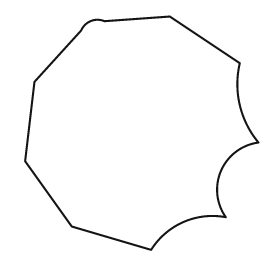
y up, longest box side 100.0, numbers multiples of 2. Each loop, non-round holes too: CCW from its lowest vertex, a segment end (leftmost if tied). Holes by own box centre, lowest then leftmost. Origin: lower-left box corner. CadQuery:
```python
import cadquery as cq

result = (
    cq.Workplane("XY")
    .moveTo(54.0, 0.0)
    .threePointArc((68.0, 12.0), (86.0, 14.0))
    .threePointArc((84.0, 34.0), (100.0, 46.0))
    .threePointArc((92.0, 62.0), (92.0, 80.0))
    .lineTo(62.0, 100.0)
    .lineTo(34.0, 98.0)
    .threePointArc((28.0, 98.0), (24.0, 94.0))
    .lineTo(4.0, 72.0)
    .lineTo(0.0, 38.0)
    .lineTo(20.0, 10.0)
    .close()
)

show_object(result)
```